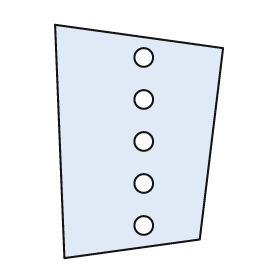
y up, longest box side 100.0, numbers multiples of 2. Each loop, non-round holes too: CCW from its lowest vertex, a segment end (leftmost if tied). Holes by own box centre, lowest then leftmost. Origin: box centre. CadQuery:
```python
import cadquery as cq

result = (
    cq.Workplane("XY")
    .moveTo(-32.0, -50.0)
    .lineTo(26.0, -42.0)
    .lineTo(36.0, 40.0)
    .lineTo(-36.0, 50.0)
    .close()
    .moveTo(2.0, -36.0)
    .circle(4.0)
    .moveTo(2.0, -18.0)
    .circle(4.0)
    .moveTo(2.0, 0.0)
    .circle(4.0)
    .moveTo(2.0, 18.0)
    .circle(4.0)
    .moveTo(2.0, 36.0)
    .circle(4.0)
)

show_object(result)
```